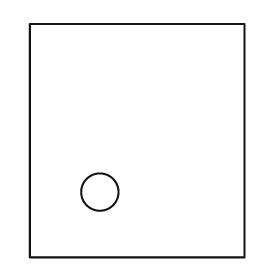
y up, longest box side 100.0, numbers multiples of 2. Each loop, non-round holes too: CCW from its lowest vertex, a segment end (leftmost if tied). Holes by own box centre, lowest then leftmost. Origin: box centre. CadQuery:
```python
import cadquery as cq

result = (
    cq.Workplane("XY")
    .moveTo(-46.0, -50.0)
    .lineTo(46.0, -50.0)
    .lineTo(46.0, 50.0)
    .lineTo(-46.0, 50.0)
    .close()
    .moveTo(-16.0, -22.0)
    .circle(8.0)
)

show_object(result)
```